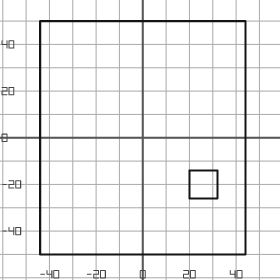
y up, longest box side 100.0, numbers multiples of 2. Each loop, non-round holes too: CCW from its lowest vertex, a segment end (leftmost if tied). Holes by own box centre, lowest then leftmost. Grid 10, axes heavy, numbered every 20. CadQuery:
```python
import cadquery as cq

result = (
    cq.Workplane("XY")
    .moveTo(-44.0, -50.0)
    .lineTo(44.0, -50.0)
    .lineTo(44.0, 50.0)
    .lineTo(-44.0, 50.0)
    .close()
    .moveTo(20.0, -26.0)
    .lineTo(32.0, -26.0)
    .lineTo(32.0, -14.0)
    .lineTo(20.0, -14.0)
    .close()
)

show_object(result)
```